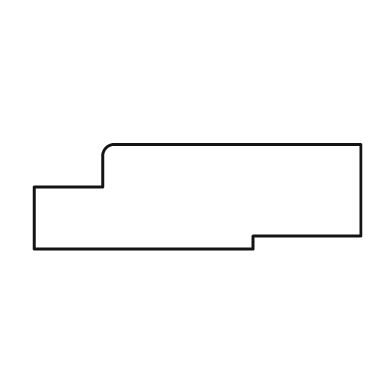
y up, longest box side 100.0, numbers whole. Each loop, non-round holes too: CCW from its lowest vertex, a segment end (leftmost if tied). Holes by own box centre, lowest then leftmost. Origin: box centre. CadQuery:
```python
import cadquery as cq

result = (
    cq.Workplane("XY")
    .moveTo(-50.0, -16.0)
    .lineTo(17.0, -16.0)
    .lineTo(17.0, -12.0)
    .lineTo(50.0, -12.0)
    .lineTo(50.0, 16.0)
    .lineTo(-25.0, 16.0)
    .threePointArc((-28.0, 15.0), (-29.0, 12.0))
    .lineTo(-29.0, 3.0)
    .lineTo(-50.0, 3.0)
    .close()
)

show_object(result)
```